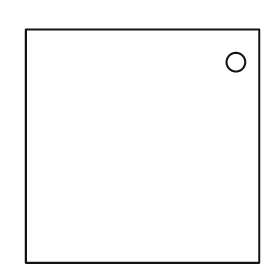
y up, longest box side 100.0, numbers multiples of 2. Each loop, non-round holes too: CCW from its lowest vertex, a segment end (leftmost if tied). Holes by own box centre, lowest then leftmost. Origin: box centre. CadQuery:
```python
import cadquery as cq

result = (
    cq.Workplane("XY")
    .moveTo(-50.0, -50.0)
    .lineTo(50.0, -50.0)
    .lineTo(50.0, 50.0)
    .lineTo(-50.0, 50.0)
    .close()
    .moveTo(40.0, 36.0)
    .circle(4.0)
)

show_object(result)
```